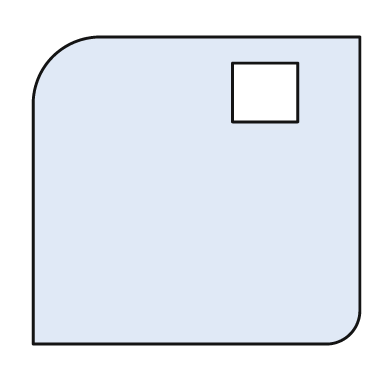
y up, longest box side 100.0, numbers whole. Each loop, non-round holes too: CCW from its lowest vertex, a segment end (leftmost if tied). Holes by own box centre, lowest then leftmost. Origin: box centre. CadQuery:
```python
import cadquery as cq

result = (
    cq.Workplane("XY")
    .moveTo(-50.0, -47.0)
    .lineTo(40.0, -47.0)
    .threePointArc((47.0, -44.0), (50.0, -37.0))
    .lineTo(50.0, 47.0)
    .lineTo(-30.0, 47.0)
    .threePointArc((-44.0, 41.0), (-50.0, 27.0))
    .close()
    .moveTo(11.0, 21.0)
    .lineTo(31.0, 21.0)
    .lineTo(31.0, 39.0)
    .lineTo(11.0, 39.0)
    .close()
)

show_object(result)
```